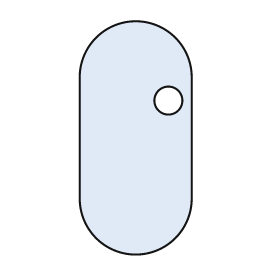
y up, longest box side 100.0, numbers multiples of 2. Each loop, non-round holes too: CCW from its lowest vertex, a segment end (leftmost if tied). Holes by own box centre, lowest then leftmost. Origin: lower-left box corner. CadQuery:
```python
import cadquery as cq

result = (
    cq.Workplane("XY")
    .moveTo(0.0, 24.0)
    .threePointArc((24.0, 0.0), (48.0, 24.0))
    .lineTo(48.0, 76.0)
    .threePointArc((24.0, 100.0), (0.0, 76.0))
    .close()
    .moveTo(38.0, 66.0)
    .circle(6.0)
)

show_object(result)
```